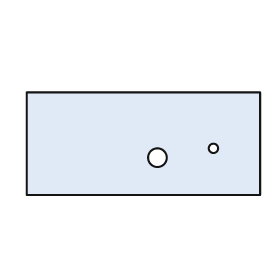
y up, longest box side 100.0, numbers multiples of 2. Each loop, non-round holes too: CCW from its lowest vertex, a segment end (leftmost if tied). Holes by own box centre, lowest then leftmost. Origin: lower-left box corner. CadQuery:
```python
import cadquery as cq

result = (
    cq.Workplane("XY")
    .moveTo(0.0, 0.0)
    .lineTo(100.0, 0.0)
    .lineTo(100.0, 44.0)
    .lineTo(0.0, 44.0)
    .close()
    .moveTo(56.0, 16.0)
    .circle(4.0)
    .moveTo(80.0, 20.0)
    .circle(2.0)
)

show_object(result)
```